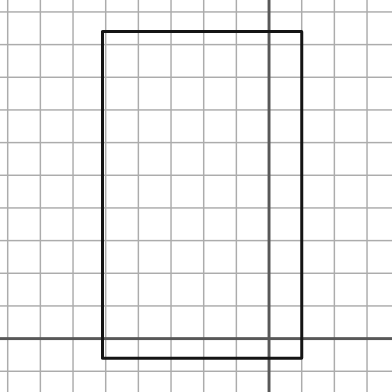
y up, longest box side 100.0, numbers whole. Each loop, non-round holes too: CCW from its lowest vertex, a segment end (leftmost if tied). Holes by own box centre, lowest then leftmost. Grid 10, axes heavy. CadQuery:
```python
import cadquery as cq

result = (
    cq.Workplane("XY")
    .moveTo(-51.0, -6.0)
    .lineTo(10.0, -6.0)
    .lineTo(10.0, 94.0)
    .lineTo(-51.0, 94.0)
    .close()
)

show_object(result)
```